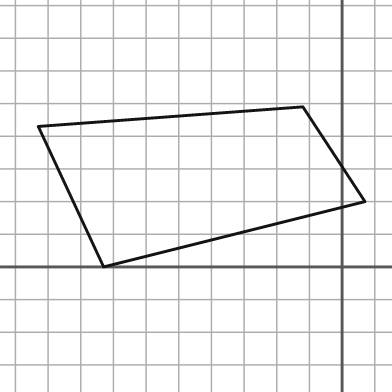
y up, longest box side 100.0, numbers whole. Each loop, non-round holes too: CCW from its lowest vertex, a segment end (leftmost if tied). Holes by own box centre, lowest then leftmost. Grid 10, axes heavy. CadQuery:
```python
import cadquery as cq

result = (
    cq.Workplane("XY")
    .moveTo(-73.0, 0.0)
    .lineTo(7.0, 20.0)
    .lineTo(-12.0, 49.0)
    .lineTo(-93.0, 43.0)
    .close()
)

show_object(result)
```